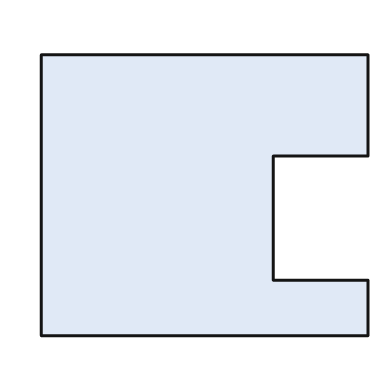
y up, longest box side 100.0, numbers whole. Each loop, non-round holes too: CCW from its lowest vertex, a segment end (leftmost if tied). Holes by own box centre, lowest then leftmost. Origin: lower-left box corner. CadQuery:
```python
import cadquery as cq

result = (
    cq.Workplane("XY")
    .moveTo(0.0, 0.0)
    .lineTo(100.0, 0.0)
    .lineTo(100.0, 17.0)
    .lineTo(71.0, 17.0)
    .lineTo(71.0, 55.0)
    .lineTo(100.0, 55.0)
    .lineTo(100.0, 86.0)
    .lineTo(0.0, 86.0)
    .close()
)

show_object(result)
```